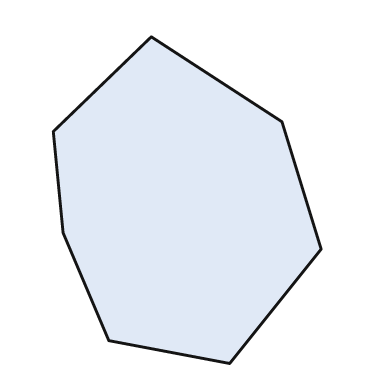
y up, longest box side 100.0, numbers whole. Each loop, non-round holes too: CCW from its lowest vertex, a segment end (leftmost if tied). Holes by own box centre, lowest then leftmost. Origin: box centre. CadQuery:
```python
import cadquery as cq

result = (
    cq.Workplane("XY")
    .moveTo(13.0, -50.0)
    .lineTo(41.0, -15.0)
    .lineTo(29.0, 24.0)
    .lineTo(-11.0, 50.0)
    .lineTo(-41.0, 21.0)
    .lineTo(-38.0, -10.0)
    .lineTo(-24.0, -43.0)
    .close()
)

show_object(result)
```